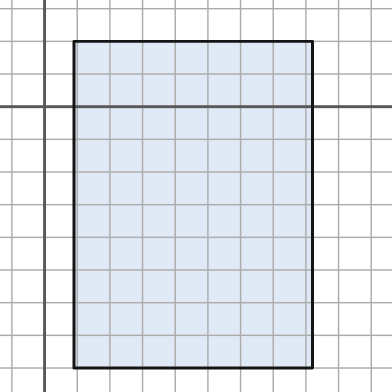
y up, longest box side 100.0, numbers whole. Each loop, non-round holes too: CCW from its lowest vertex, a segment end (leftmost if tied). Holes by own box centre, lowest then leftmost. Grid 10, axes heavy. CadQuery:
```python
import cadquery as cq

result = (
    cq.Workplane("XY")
    .moveTo(9.0, -80.0)
    .lineTo(82.0, -80.0)
    .lineTo(82.0, 20.0)
    .lineTo(9.0, 20.0)
    .close()
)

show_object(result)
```